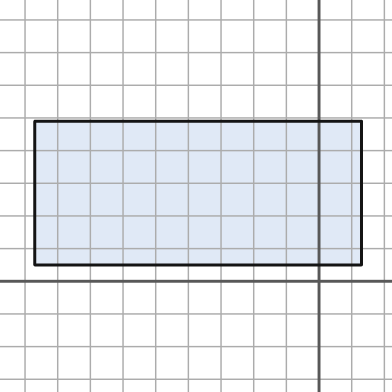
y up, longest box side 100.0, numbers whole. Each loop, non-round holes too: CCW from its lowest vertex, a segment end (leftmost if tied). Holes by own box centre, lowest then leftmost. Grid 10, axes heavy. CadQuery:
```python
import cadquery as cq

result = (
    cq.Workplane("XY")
    .moveTo(-87.0, 5.0)
    .lineTo(13.0, 5.0)
    .lineTo(13.0, 49.0)
    .lineTo(-87.0, 49.0)
    .close()
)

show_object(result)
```